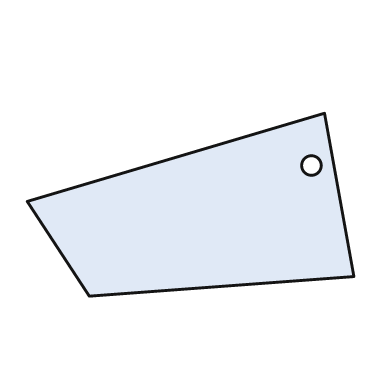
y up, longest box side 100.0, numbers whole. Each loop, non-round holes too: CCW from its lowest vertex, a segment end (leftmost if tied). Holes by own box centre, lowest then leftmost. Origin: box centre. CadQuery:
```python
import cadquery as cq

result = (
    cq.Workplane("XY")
    .moveTo(-31.0, -28.0)
    .lineTo(50.0, -22.0)
    .lineTo(41.0, 28.0)
    .lineTo(-50.0, 1.0)
    .close()
    .moveTo(37.0, 12.0)
    .circle(3.0)
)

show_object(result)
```